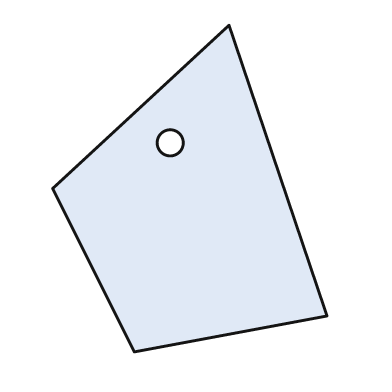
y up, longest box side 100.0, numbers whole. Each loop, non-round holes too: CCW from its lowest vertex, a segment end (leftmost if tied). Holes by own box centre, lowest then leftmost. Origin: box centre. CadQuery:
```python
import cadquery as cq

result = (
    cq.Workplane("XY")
    .moveTo(-17.0, -50.0)
    .lineTo(42.0, -39.0)
    .lineTo(12.0, 50.0)
    .lineTo(-42.0, 0.0)
    .close()
    .moveTo(-6.0, 14.0)
    .circle(4.0)
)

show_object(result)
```